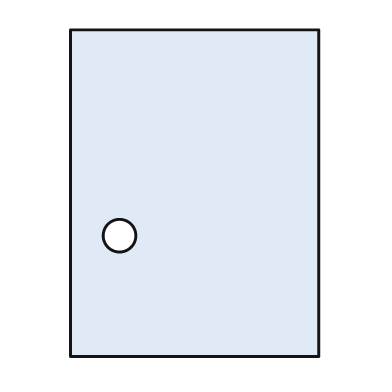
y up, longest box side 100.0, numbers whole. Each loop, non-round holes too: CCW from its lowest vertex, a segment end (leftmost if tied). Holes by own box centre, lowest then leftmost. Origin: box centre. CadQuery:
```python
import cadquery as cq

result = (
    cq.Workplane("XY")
    .moveTo(-38.0, -50.0)
    .lineTo(38.0, -50.0)
    .lineTo(38.0, 50.0)
    .lineTo(-38.0, 50.0)
    .close()
    .moveTo(-23.0, -13.0)
    .circle(5.0)
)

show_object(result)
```